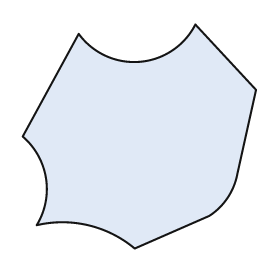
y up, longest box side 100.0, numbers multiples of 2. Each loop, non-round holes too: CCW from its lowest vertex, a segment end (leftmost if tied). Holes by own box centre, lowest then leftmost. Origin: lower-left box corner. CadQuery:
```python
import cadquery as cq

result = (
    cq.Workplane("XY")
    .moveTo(48.0, 0.0)
    .lineTo(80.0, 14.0)
    .threePointArc((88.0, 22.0), (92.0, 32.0))
    .lineTo(100.0, 68.0)
    .lineTo(74.0, 96.0)
    .threePointArc((50.0, 80.0), (24.0, 92.0))
    .lineTo(0.0, 48.0)
    .threePointArc((10.0, 30.0), (6.0, 10.0))
    .threePointArc((28.0, 10.0), (48.0, 0.0))
    .close()
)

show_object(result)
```